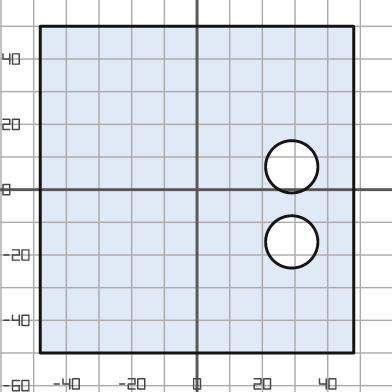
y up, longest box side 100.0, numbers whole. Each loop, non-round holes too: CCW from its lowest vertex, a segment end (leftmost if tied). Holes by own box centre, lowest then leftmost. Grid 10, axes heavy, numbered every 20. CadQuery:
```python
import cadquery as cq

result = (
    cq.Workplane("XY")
    .moveTo(-48.0, -50.0)
    .lineTo(48.0, -50.0)
    .lineTo(48.0, 50.0)
    .lineTo(-48.0, 50.0)
    .close()
    .moveTo(29.0, -16.0)
    .circle(8.0)
    .moveTo(29.0, 7.0)
    .circle(8.0)
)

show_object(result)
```